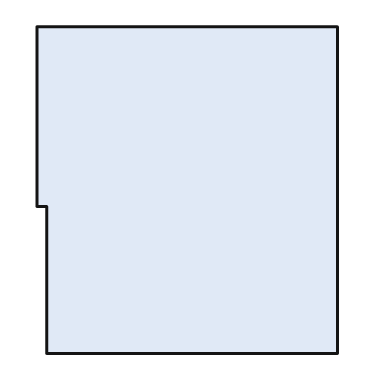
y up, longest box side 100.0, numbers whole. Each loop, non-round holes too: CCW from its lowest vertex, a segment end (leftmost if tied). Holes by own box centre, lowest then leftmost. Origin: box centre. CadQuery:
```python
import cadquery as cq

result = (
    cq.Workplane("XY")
    .moveTo(-43.0, -50.0)
    .lineTo(46.0, -50.0)
    .lineTo(46.0, 50.0)
    .lineTo(-46.0, 50.0)
    .lineTo(-46.0, -5.0)
    .lineTo(-43.0, -5.0)
    .close()
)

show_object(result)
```